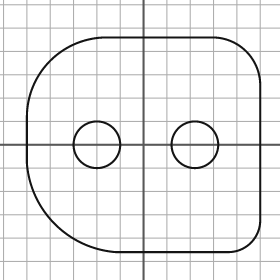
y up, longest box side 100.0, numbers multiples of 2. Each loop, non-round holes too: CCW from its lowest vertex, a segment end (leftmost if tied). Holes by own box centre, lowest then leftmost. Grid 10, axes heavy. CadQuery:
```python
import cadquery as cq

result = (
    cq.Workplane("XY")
    .moveTo(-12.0, -46.0)
    .lineTo(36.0, -46.0)
    .threePointArc((46.0, -42.0), (50.0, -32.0))
    .lineTo(50.0, 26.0)
    .threePointArc((44.0, 40.0), (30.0, 46.0))
    .lineTo(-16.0, 46.0)
    .threePointArc((-40.0, 36.0), (-50.0, 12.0))
    .lineTo(-50.0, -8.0)
    .threePointArc((-38.0, -34.0), (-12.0, -46.0))
    .close()
    .moveTo(-20.0, 0.0)
    .circle(10.0)
    .moveTo(22.0, 0.0)
    .circle(10.0)
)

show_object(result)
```